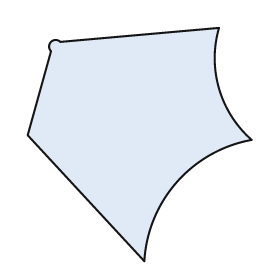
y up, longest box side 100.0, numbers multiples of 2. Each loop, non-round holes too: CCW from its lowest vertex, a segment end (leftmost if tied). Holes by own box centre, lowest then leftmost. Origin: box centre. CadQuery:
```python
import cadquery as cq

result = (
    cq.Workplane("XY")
    .moveTo(2.0, -50.0)
    .threePointArc((16.0, -16.0), (48.0, 2.0))
    .threePointArc((34.0, 24.0), (34.0, 50.0))
    .lineTo(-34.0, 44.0)
    .threePointArc((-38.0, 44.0), (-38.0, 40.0))
    .lineTo(-48.0, 4.0)
    .close()
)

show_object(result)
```